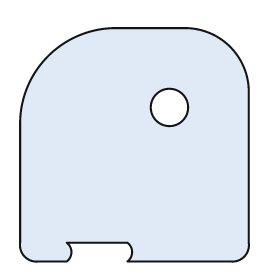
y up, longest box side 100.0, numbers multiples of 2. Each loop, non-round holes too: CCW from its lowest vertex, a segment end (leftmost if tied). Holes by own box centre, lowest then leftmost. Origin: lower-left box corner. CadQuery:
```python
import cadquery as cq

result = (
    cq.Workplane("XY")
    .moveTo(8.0, 0.0)
    .lineTo(20.0, 0.0)
    .threePointArc((22.0, 4.0), (20.0, 8.0))
    .lineTo(46.0, 8.0)
    .threePointArc((48.0, 4.0), (46.0, 0.0))
    .lineTo(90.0, 0.0)
    .threePointArc((96.0, 2.0), (98.0, 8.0))
    .lineTo(98.0, 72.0)
    .threePointArc((90.0, 92.0), (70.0, 100.0))
    .lineTo(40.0, 100.0)
    .threePointArc((12.0, 88.0), (0.0, 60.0))
    .lineTo(0.0, 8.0)
    .threePointArc((2.0, 2.0), (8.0, 0.0))
    .close()
    .moveTo(64.0, 66.0)
    .circle(8.0)
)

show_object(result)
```